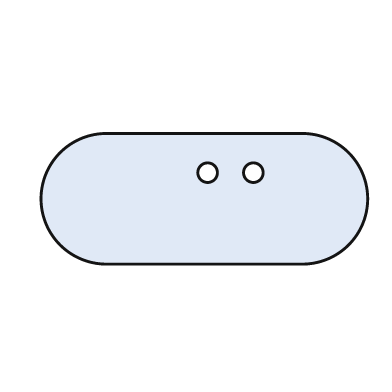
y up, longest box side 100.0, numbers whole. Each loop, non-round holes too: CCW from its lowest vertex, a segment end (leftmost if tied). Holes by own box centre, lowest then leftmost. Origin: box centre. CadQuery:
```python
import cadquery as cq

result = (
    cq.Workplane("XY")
    .moveTo(-30.0, -20.0)
    .lineTo(30.0, -20.0)
    .threePointArc((50.0, 0.0), (30.0, 20.0))
    .lineTo(-30.0, 20.0)
    .threePointArc((-50.0, 0.0), (-30.0, -20.0))
    .close()
    .moveTo(1.0, 8.0)
    .circle(3.0)
    .moveTo(15.0, 8.0)
    .circle(3.0)
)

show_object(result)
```